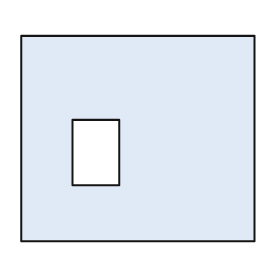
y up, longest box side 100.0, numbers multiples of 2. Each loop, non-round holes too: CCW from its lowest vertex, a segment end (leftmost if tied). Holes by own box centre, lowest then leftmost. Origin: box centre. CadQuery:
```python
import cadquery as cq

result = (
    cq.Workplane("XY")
    .moveTo(-50.0, -44.0)
    .lineTo(50.0, -44.0)
    .lineTo(50.0, 44.0)
    .lineTo(-50.0, 44.0)
    .close()
    .moveTo(-28.0, -20.0)
    .lineTo(-8.0, -20.0)
    .lineTo(-8.0, 8.0)
    .lineTo(-28.0, 8.0)
    .close()
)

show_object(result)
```